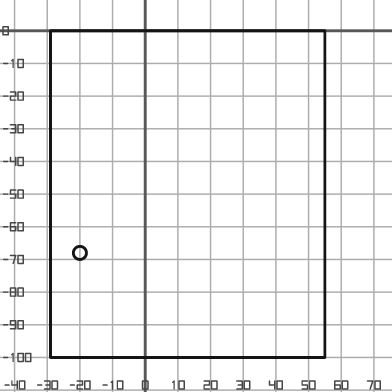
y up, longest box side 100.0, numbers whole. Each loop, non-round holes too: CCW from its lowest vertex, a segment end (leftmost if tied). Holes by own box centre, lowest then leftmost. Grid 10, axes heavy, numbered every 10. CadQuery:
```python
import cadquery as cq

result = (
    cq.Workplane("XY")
    .moveTo(-29.0, -100.0)
    .lineTo(55.0, -100.0)
    .lineTo(55.0, 0.0)
    .lineTo(-29.0, 0.0)
    .close()
    .moveTo(-20.0, -68.0)
    .circle(2.0)
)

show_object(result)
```